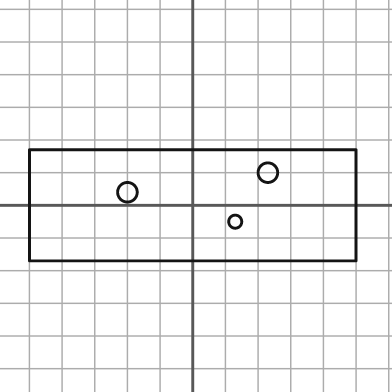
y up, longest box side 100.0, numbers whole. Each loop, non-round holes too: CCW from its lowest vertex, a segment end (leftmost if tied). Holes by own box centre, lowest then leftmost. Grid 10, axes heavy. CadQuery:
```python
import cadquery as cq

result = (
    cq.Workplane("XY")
    .moveTo(-50.0, -17.0)
    .lineTo(50.0, -17.0)
    .lineTo(50.0, 17.0)
    .lineTo(-50.0, 17.0)
    .close()
    .moveTo(13.0, -5.0)
    .circle(2.0)
    .moveTo(-20.0, 4.0)
    .circle(3.0)
    .moveTo(23.0, 10.0)
    .circle(3.0)
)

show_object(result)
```